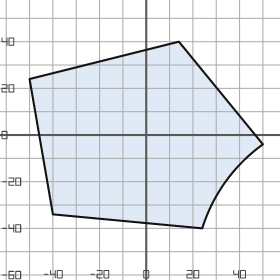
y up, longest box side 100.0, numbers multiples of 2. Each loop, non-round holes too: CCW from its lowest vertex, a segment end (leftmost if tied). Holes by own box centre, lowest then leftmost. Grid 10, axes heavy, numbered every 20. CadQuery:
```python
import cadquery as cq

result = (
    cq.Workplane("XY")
    .moveTo(24.0, -40.0)
    .threePointArc((34.0, -20.0), (50.0, -4.0))
    .lineTo(14.0, 40.0)
    .lineTo(-50.0, 24.0)
    .lineTo(-40.0, -34.0)
    .close()
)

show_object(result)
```